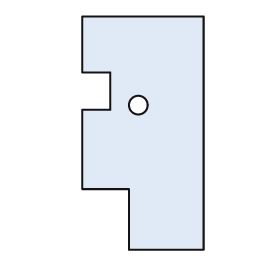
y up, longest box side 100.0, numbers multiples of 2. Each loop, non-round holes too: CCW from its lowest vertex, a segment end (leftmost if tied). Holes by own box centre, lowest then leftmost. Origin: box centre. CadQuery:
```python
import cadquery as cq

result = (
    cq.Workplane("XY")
    .moveTo(-6.0, -50.0)
    .lineTo(26.0, -50.0)
    .lineTo(26.0, 50.0)
    .lineTo(-26.0, 50.0)
    .lineTo(-26.0, 26.0)
    .lineTo(-14.0, 26.0)
    .lineTo(-14.0, 10.0)
    .lineTo(-26.0, 10.0)
    .lineTo(-26.0, -24.0)
    .lineTo(-6.0, -24.0)
    .close()
    .moveTo(-2.0, 12.0)
    .circle(4.0)
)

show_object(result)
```